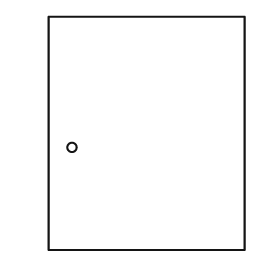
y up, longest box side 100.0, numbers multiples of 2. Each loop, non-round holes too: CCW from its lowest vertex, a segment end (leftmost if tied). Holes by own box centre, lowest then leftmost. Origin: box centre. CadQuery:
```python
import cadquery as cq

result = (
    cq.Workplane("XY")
    .moveTo(-42.0, -50.0)
    .lineTo(42.0, -50.0)
    .lineTo(42.0, 50.0)
    .lineTo(-42.0, 50.0)
    .close()
    .moveTo(-32.0, -6.0)
    .circle(2.0)
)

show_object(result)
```